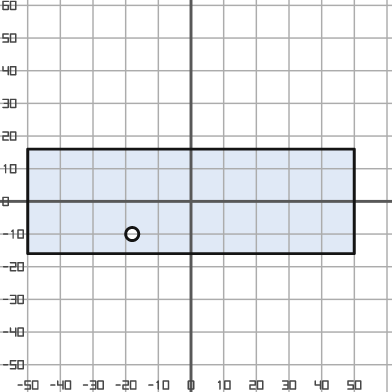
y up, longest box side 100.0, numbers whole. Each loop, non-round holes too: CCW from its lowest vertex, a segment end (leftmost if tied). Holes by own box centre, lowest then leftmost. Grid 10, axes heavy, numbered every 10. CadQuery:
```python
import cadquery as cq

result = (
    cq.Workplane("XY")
    .moveTo(-50.0, -16.0)
    .lineTo(50.0, -16.0)
    .lineTo(50.0, 16.0)
    .lineTo(-50.0, 16.0)
    .close()
    .moveTo(-18.0, -10.0)
    .circle(2.0)
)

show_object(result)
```